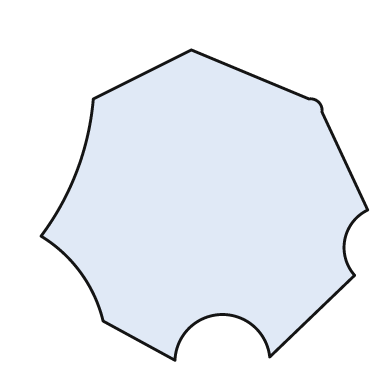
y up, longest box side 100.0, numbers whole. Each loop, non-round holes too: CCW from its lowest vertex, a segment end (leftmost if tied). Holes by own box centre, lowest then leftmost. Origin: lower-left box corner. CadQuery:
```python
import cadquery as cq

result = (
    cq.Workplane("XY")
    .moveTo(41.0, 0.0)
    .threePointArc((55.0, 14.0), (70.0, 1.0))
    .lineTo(96.0, 26.0)
    .threePointArc((93.0, 37.0), (100.0, 46.0))
    .lineTo(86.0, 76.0)
    .threePointArc((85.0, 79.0), (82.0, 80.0))
    .lineTo(46.0, 95.0)
    .lineTo(16.0, 80.0)
    .threePointArc((11.0, 58.0), (0.0, 38.0))
    .threePointArc((12.0, 27.0), (19.0, 12.0))
    .close()
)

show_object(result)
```